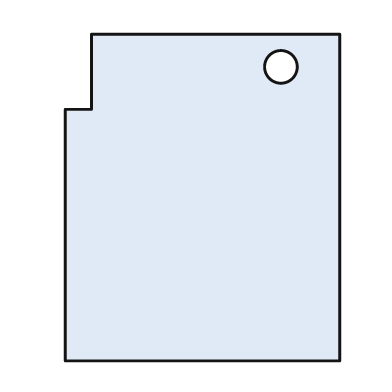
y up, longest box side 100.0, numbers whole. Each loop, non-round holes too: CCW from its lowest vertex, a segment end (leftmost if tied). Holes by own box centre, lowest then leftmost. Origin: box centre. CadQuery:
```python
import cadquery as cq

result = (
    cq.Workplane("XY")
    .moveTo(-42.0, -50.0)
    .lineTo(42.0, -50.0)
    .lineTo(42.0, 50.0)
    .lineTo(-34.0, 50.0)
    .lineTo(-34.0, 27.0)
    .lineTo(-42.0, 27.0)
    .close()
    .moveTo(24.0, 40.0)
    .circle(5.0)
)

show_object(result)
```